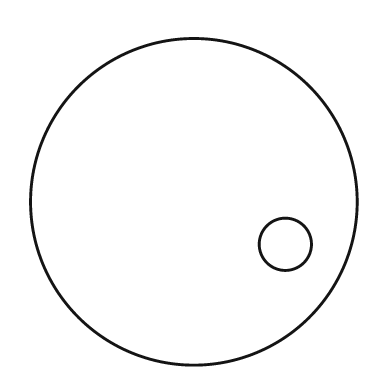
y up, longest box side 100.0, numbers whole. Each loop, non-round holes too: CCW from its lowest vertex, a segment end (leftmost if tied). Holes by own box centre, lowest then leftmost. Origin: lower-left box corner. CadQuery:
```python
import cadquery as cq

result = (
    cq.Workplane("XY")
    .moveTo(50.0, 50.0)
    .circle(50.0)
    .moveTo(78.0, 37.0)
    .circle(8.0)
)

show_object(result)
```